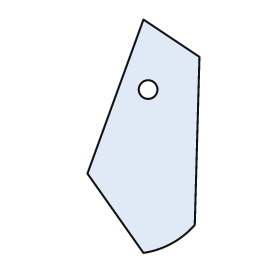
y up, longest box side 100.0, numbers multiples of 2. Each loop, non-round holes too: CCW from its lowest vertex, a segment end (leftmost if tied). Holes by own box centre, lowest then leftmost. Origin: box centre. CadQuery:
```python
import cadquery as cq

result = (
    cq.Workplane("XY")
    .moveTo(0.0, -50.0)
    .threePointArc((12.0, -46.0), (22.0, -38.0))
    .lineTo(24.0, 34.0)
    .lineTo(0.0, 50.0)
    .lineTo(-24.0, -16.0)
    .close()
    .moveTo(2.0, 20.0)
    .circle(4.0)
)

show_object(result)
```